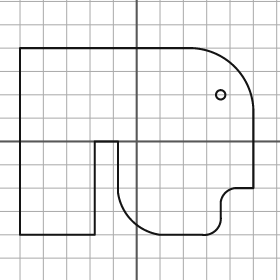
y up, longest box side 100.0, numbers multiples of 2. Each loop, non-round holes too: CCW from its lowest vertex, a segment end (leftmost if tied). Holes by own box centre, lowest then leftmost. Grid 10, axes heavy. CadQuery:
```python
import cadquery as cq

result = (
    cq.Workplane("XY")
    .moveTo(-50.0, -40.0)
    .lineTo(-18.0, -40.0)
    .lineTo(-18.0, 0.0)
    .lineTo(-8.0, 0.0)
    .lineTo(-8.0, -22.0)
    .threePointArc((-2.0, -34.0), (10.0, -40.0))
    .lineTo(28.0, -40.0)
    .threePointArc((34.0, -38.0), (36.0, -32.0))
    .lineTo(36.0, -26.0)
    .threePointArc((38.0, -22.0), (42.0, -20.0))
    .lineTo(50.0, -20.0)
    .lineTo(50.0, 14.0)
    .threePointArc((42.0, 32.0), (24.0, 40.0))
    .lineTo(-50.0, 40.0)
    .close()
    .moveTo(36.0, 20.0)
    .circle(2.0)
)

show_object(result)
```